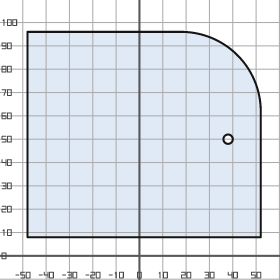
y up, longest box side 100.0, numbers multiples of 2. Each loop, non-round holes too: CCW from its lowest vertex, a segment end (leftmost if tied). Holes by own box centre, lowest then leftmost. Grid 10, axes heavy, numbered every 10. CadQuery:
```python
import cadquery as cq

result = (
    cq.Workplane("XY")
    .moveTo(-48.0, 8.0)
    .lineTo(52.0, 8.0)
    .lineTo(52.0, 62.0)
    .threePointArc((42.0, 86.0), (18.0, 96.0))
    .lineTo(-48.0, 96.0)
    .close()
    .moveTo(38.0, 50.0)
    .circle(2.0)
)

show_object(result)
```